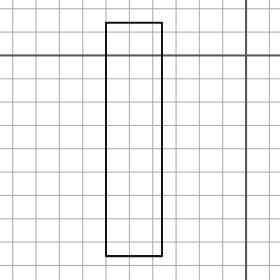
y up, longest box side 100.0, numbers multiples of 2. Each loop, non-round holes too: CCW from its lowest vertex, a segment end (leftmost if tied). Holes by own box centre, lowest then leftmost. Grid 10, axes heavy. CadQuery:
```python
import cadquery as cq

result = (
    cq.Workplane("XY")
    .moveTo(-60.0, -86.0)
    .lineTo(-36.0, -86.0)
    .lineTo(-36.0, 14.0)
    .lineTo(-60.0, 14.0)
    .close()
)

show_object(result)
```